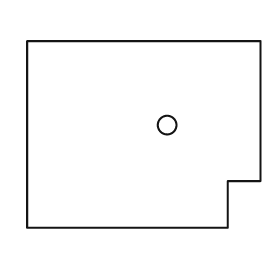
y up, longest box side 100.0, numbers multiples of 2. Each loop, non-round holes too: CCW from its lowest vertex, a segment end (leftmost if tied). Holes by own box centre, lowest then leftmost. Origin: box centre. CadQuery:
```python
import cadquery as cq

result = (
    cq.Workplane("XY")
    .moveTo(-50.0, -40.0)
    .lineTo(36.0, -40.0)
    .lineTo(36.0, -20.0)
    .lineTo(50.0, -20.0)
    .lineTo(50.0, 40.0)
    .lineTo(-50.0, 40.0)
    .close()
    .moveTo(10.0, 4.0)
    .circle(4.0)
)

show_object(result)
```